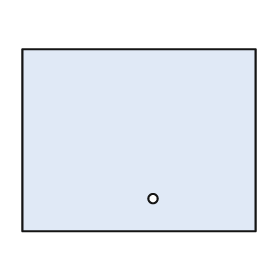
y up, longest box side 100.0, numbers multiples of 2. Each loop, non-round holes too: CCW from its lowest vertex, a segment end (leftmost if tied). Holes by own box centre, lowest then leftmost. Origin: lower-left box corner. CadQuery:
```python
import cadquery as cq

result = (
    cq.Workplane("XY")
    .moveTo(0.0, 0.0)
    .lineTo(100.0, 0.0)
    .lineTo(100.0, 78.0)
    .lineTo(0.0, 78.0)
    .close()
    .moveTo(56.0, 14.0)
    .circle(2.0)
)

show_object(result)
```